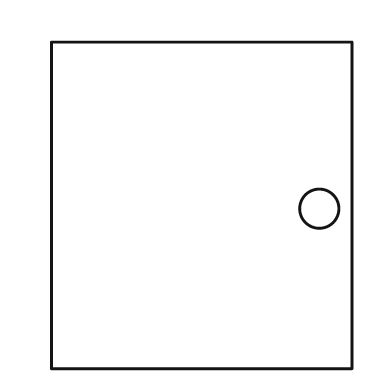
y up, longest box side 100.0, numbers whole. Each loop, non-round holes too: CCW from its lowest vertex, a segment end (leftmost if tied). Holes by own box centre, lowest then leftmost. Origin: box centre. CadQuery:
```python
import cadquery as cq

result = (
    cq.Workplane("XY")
    .moveTo(-46.0, -50.0)
    .lineTo(46.0, -50.0)
    .lineTo(46.0, 50.0)
    .lineTo(-46.0, 50.0)
    .close()
    .moveTo(36.0, -1.0)
    .circle(6.0)
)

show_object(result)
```